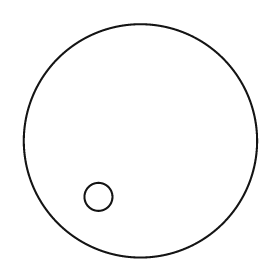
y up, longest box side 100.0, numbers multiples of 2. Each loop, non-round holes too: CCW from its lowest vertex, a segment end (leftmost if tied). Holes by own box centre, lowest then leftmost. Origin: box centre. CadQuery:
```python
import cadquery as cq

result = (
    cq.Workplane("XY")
    .moveTo(0.0, 0.0)
    .circle(50.0)
    .moveTo(-18.0, -24.0)
    .circle(6.0)
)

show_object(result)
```